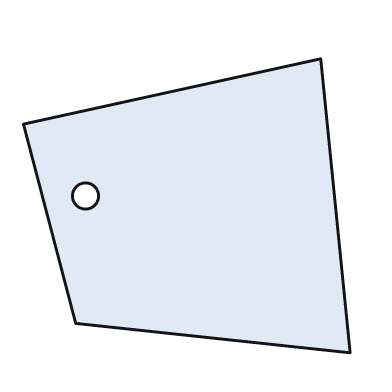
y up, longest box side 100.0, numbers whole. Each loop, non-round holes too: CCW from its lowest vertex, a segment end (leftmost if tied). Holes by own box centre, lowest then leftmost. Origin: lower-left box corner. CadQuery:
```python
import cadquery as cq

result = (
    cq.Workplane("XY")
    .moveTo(100.0, 0.0)
    .lineTo(91.0, 90.0)
    .lineTo(0.0, 70.0)
    .lineTo(16.0, 9.0)
    .close()
    .moveTo(19.0, 48.0)
    .circle(4.0)
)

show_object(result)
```